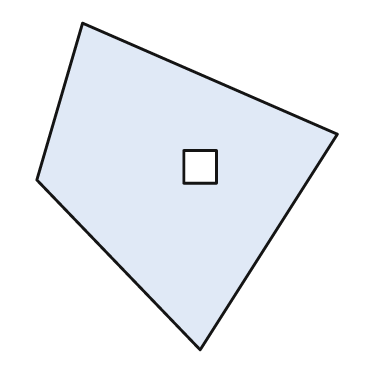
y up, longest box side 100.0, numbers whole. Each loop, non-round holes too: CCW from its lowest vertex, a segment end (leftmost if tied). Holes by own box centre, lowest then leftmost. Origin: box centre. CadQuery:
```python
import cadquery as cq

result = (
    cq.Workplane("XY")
    .moveTo(4.0, -50.0)
    .lineTo(46.0, 16.0)
    .lineTo(-32.0, 50.0)
    .lineTo(-46.0, 2.0)
    .close()
    .moveTo(-1.0, 1.0)
    .lineTo(9.0, 1.0)
    .lineTo(9.0, 11.0)
    .lineTo(-1.0, 11.0)
    .close()
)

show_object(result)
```